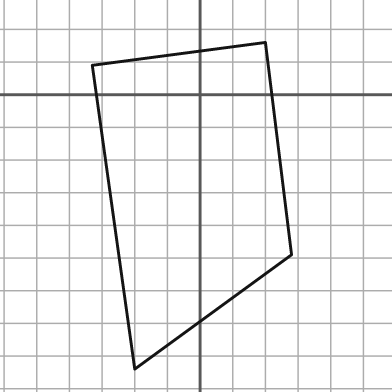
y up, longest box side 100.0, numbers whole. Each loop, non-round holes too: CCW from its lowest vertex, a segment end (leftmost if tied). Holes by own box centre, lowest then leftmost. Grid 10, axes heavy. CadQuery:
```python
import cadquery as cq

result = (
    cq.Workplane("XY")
    .moveTo(-20.0, -84.0)
    .lineTo(28.0, -49.0)
    .lineTo(20.0, 16.0)
    .lineTo(-33.0, 9.0)
    .close()
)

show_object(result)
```